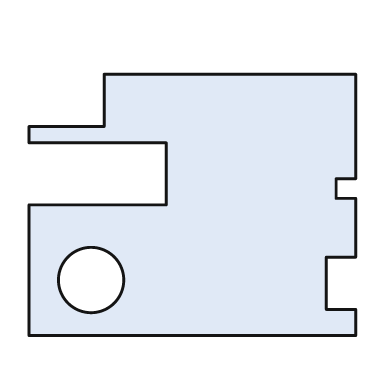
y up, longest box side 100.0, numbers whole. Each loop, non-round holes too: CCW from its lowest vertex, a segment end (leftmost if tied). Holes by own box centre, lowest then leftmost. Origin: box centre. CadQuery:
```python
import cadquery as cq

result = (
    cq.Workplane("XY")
    .moveTo(-50.0, -40.0)
    .lineTo(50.0, -40.0)
    .lineTo(50.0, -32.0)
    .lineTo(41.0, -32.0)
    .lineTo(41.0, -16.0)
    .lineTo(50.0, -16.0)
    .lineTo(50.0, 2.0)
    .lineTo(44.0, 2.0)
    .lineTo(44.0, 8.0)
    .lineTo(50.0, 8.0)
    .lineTo(50.0, 40.0)
    .lineTo(-27.0, 40.0)
    .lineTo(-27.0, 24.0)
    .lineTo(-50.0, 24.0)
    .lineTo(-50.0, 19.0)
    .lineTo(-8.0, 19.0)
    .lineTo(-8.0, 0.0)
    .lineTo(-50.0, 0.0)
    .close()
    .moveTo(-31.0, -23.0)
    .circle(10.0)
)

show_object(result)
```